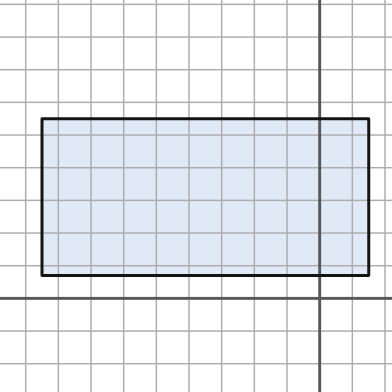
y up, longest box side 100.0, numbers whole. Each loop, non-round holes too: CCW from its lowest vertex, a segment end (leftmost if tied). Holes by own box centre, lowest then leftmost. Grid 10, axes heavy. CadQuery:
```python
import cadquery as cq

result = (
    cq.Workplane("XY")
    .moveTo(-85.0, 7.0)
    .lineTo(15.0, 7.0)
    .lineTo(15.0, 55.0)
    .lineTo(-85.0, 55.0)
    .close()
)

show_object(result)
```